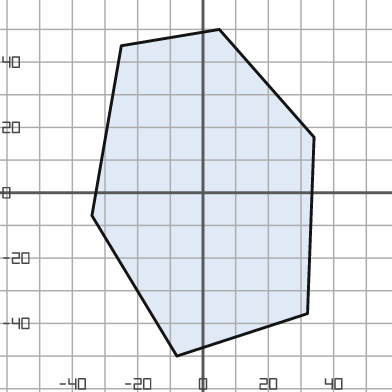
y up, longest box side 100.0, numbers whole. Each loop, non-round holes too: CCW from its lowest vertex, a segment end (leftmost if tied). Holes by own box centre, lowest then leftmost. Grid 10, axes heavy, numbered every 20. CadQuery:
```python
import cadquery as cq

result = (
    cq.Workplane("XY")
    .moveTo(-8.0, -50.0)
    .lineTo(32.0, -37.0)
    .lineTo(34.0, 17.0)
    .lineTo(5.0, 50.0)
    .lineTo(-25.0, 45.0)
    .lineTo(-34.0, -7.0)
    .close()
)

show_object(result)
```